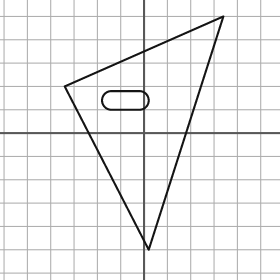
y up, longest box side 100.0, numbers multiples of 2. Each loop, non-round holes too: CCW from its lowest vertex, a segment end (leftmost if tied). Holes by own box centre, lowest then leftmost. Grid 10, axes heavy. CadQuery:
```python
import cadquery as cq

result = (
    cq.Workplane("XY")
    .moveTo(2.0, -50.0)
    .lineTo(34.0, 50.0)
    .lineTo(-34.0, 20.0)
    .close()
    .moveTo(-14.0, 10.0)
    .lineTo(-2.0, 10.0)
    .threePointArc((2.0, 14.0), (-2.0, 18.0))
    .lineTo(-14.0, 18.0)
    .threePointArc((-18.0, 14.0), (-14.0, 10.0))
    .close()
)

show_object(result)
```